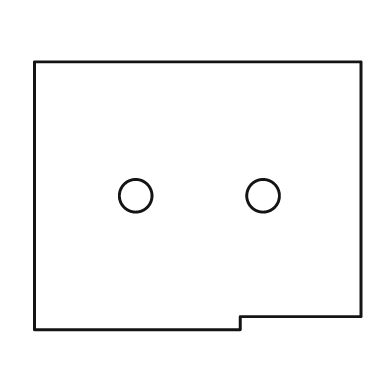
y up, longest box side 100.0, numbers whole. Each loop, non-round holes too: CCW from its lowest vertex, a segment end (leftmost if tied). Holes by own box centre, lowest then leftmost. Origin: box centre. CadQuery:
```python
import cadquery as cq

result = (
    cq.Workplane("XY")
    .moveTo(-50.0, -41.0)
    .lineTo(13.0, -41.0)
    .lineTo(13.0, -37.0)
    .lineTo(50.0, -37.0)
    .lineTo(50.0, 41.0)
    .lineTo(-50.0, 41.0)
    .close()
    .moveTo(-19.0, 0.0)
    .circle(5.0)
    .moveTo(20.0, 0.0)
    .circle(5.0)
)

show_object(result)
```